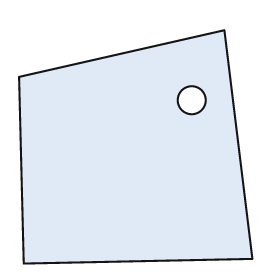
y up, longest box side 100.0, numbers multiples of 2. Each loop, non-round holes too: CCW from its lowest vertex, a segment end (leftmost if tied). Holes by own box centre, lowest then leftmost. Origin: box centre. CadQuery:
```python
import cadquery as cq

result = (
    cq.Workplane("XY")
    .moveTo(-48.0, -50.0)
    .lineTo(50.0, -48.0)
    .lineTo(38.0, 50.0)
    .lineTo(-50.0, 30.0)
    .close()
    .moveTo(24.0, 20.0)
    .circle(6.0)
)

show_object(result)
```